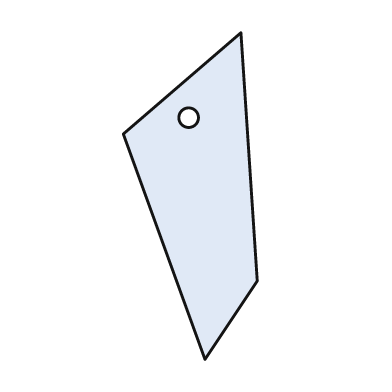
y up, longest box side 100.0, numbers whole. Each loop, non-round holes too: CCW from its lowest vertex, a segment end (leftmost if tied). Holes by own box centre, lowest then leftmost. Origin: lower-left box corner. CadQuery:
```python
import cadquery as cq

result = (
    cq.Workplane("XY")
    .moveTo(25.0, 0.0)
    .lineTo(41.0, 24.0)
    .lineTo(36.0, 100.0)
    .lineTo(0.0, 69.0)
    .close()
    .moveTo(20.0, 74.0)
    .circle(3.0)
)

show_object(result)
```